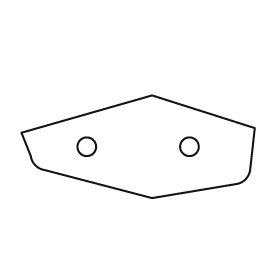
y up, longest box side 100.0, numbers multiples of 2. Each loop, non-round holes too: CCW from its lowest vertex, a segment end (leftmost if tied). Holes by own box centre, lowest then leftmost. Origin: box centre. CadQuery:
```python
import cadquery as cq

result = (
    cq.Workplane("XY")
    .moveTo(6.0, -22.0)
    .lineTo(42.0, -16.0)
    .threePointArc((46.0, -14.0), (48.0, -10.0))
    .lineTo(50.0, 8.0)
    .lineTo(6.0, 22.0)
    .lineTo(-50.0, 6.0)
    .lineTo(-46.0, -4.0)
    .threePointArc((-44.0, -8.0), (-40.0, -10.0))
    .close()
    .moveTo(-22.0, 0.0)
    .circle(4.0)
    .moveTo(22.0, 0.0)
    .circle(4.0)
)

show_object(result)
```